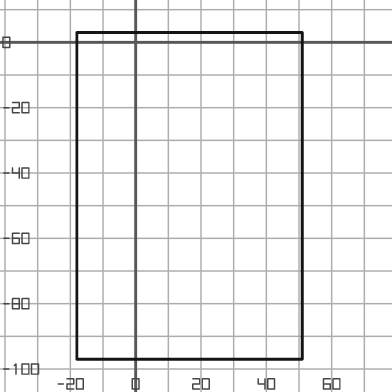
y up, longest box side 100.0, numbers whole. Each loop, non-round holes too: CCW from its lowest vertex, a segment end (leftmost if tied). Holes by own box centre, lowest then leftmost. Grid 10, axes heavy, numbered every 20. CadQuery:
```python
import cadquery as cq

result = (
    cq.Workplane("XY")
    .moveTo(-18.0, -97.0)
    .lineTo(51.0, -97.0)
    .lineTo(51.0, 3.0)
    .lineTo(-18.0, 3.0)
    .close()
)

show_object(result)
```